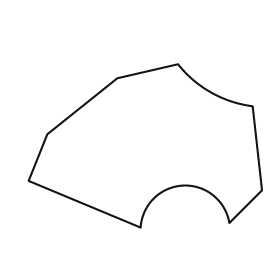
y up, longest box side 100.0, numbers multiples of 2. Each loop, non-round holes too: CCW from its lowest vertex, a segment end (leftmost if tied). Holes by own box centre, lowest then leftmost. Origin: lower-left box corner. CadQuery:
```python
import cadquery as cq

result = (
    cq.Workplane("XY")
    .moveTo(48.0, 0.0)
    .threePointArc((66.0, 18.0), (86.0, 2.0))
    .lineTo(100.0, 16.0)
    .lineTo(96.0, 52.0)
    .threePointArc((78.0, 58.0), (64.0, 70.0))
    .lineTo(38.0, 64.0)
    .lineTo(8.0, 40.0)
    .lineTo(0.0, 20.0)
    .close()
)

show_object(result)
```